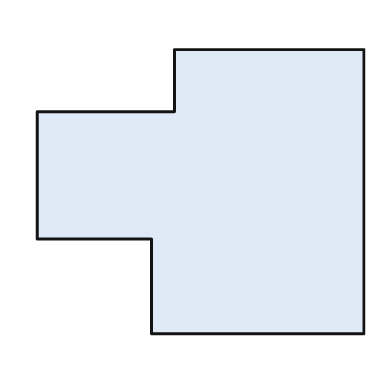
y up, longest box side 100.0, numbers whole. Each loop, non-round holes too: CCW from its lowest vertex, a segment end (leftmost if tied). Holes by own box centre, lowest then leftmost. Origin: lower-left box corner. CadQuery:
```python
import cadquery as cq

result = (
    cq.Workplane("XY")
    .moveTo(35.0, 0.0)
    .lineTo(100.0, 0.0)
    .lineTo(100.0, 87.0)
    .lineTo(42.0, 87.0)
    .lineTo(42.0, 68.0)
    .lineTo(0.0, 68.0)
    .lineTo(0.0, 29.0)
    .lineTo(35.0, 29.0)
    .close()
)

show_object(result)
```